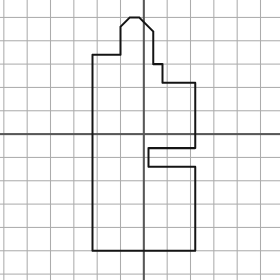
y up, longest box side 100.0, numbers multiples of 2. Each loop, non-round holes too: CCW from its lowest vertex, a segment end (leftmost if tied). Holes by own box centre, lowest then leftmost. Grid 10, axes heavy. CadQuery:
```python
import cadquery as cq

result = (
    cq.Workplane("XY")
    .moveTo(-22.0, -50.0)
    .lineTo(22.0, -50.0)
    .lineTo(22.0, -14.0)
    .lineTo(2.0, -14.0)
    .lineTo(2.0, -6.0)
    .lineTo(22.0, -6.0)
    .lineTo(22.0, 22.0)
    .lineTo(8.0, 22.0)
    .lineTo(8.0, 30.0)
    .lineTo(4.0, 30.0)
    .lineTo(4.0, 44.0)
    .lineTo(-2.0, 50.0)
    .lineTo(-6.0, 50.0)
    .lineTo(-10.0, 46.0)
    .lineTo(-10.0, 34.0)
    .lineTo(-22.0, 34.0)
    .close()
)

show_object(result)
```